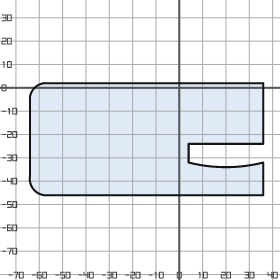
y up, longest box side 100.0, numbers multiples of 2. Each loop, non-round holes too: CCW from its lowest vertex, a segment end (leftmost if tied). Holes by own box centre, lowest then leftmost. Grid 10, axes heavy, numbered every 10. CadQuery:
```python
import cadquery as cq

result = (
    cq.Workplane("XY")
    .moveTo(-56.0, -46.0)
    .lineTo(36.0, -46.0)
    .lineTo(36.0, -32.0)
    .threePointArc((20.0, -34.0), (4.0, -32.0))
    .lineTo(4.0, -24.0)
    .lineTo(36.0, -24.0)
    .lineTo(36.0, 2.0)
    .lineTo(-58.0, 2.0)
    .threePointArc((-62.0, 0.0), (-64.0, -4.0))
    .lineTo(-64.0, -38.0)
    .threePointArc((-62.0, -44.0), (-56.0, -46.0))
    .close()
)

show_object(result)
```